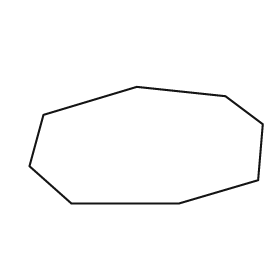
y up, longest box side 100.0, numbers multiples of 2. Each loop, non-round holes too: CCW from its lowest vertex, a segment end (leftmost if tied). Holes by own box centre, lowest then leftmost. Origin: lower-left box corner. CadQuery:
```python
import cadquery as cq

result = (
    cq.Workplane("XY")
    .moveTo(18.0, 0.0)
    .lineTo(64.0, 0.0)
    .lineTo(98.0, 10.0)
    .lineTo(100.0, 34.0)
    .lineTo(84.0, 46.0)
    .lineTo(46.0, 50.0)
    .lineTo(6.0, 38.0)
    .lineTo(0.0, 16.0)
    .close()
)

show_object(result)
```